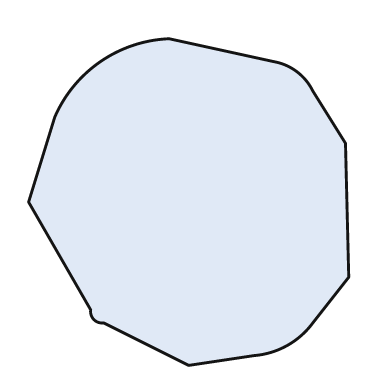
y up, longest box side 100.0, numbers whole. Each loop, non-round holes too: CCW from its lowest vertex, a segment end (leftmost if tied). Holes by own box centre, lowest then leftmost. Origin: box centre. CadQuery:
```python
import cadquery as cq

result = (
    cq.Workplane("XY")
    .moveTo(0.0, -50.0)
    .lineTo(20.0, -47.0)
    .threePointArc((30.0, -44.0), (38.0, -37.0))
    .lineTo(49.0, -23.0)
    .lineTo(48.0, 18.0)
    .lineTo(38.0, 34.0)
    .threePointArc((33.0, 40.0), (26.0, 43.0))
    .lineTo(-6.0, 50.0)
    .threePointArc((-27.0, 43.0), (-41.0, 26.0))
    .lineTo(-49.0, 0.0)
    .lineTo(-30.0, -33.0)
    .threePointArc((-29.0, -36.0), (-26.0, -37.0))
    .close()
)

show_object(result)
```